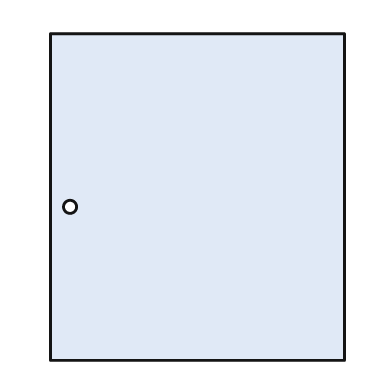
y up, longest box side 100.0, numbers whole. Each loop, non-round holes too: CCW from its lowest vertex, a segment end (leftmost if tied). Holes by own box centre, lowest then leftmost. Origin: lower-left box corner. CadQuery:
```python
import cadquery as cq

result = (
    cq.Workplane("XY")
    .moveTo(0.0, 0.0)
    .lineTo(90.0, 0.0)
    .lineTo(90.0, 100.0)
    .lineTo(0.0, 100.0)
    .close()
    .moveTo(6.0, 47.0)
    .circle(2.0)
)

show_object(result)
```